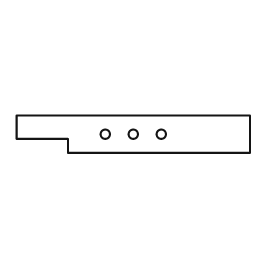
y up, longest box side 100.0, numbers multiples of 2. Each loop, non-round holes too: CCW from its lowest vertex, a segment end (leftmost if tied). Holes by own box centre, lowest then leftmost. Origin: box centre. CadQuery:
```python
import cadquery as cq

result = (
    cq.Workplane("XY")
    .moveTo(-28.0, -8.0)
    .lineTo(50.0, -8.0)
    .lineTo(50.0, 8.0)
    .lineTo(-50.0, 8.0)
    .lineTo(-50.0, -2.0)
    .lineTo(-28.0, -2.0)
    .close()
    .moveTo(-12.0, 0.0)
    .circle(2.0)
    .moveTo(0.0, 0.0)
    .circle(2.0)
    .moveTo(12.0, 0.0)
    .circle(2.0)
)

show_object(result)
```